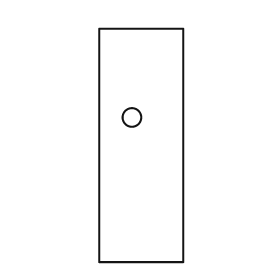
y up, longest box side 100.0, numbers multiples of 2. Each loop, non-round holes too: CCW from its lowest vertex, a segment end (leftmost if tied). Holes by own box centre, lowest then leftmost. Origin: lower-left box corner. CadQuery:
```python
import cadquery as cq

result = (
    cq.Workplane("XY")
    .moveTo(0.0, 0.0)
    .lineTo(36.0, 0.0)
    .lineTo(36.0, 100.0)
    .lineTo(0.0, 100.0)
    .close()
    .moveTo(14.0, 62.0)
    .circle(4.0)
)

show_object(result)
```